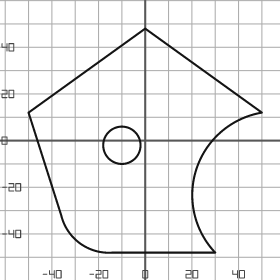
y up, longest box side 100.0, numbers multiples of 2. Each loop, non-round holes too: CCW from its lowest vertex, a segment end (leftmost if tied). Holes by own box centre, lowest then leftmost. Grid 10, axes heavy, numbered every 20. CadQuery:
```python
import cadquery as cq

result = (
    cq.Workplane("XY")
    .moveTo(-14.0, -48.0)
    .lineTo(30.0, -48.0)
    .threePointArc((22.0, -12.0), (50.0, 12.0))
    .lineTo(0.0, 48.0)
    .lineTo(-50.0, 12.0)
    .lineTo(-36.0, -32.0)
    .threePointArc((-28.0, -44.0), (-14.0, -48.0))
    .close()
    .moveTo(-10.0, -2.0)
    .circle(8.0)
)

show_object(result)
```